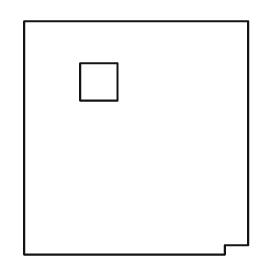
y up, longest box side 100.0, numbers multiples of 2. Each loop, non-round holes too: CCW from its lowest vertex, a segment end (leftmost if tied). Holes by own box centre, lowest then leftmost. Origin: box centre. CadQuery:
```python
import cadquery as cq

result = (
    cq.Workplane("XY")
    .moveTo(-48.0, -50.0)
    .lineTo(38.0, -50.0)
    .lineTo(38.0, -46.0)
    .lineTo(48.0, -46.0)
    .lineTo(48.0, 50.0)
    .lineTo(-48.0, 50.0)
    .close()
    .moveTo(-24.0, 16.0)
    .lineTo(-8.0, 16.0)
    .lineTo(-8.0, 32.0)
    .lineTo(-24.0, 32.0)
    .close()
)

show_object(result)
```